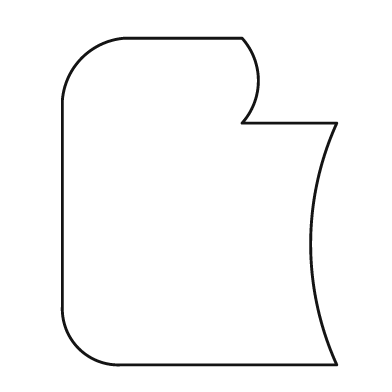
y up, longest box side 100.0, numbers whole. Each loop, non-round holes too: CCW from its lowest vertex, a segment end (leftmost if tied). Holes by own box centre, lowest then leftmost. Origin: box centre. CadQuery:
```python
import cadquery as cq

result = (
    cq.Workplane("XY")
    .moveTo(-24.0, -50.0)
    .lineTo(42.0, -50.0)
    .threePointArc((34.0, -13.0), (42.0, 24.0))
    .lineTo(13.0, 24.0)
    .threePointArc((18.0, 37.0), (13.0, 50.0))
    .lineTo(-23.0, 50.0)
    .threePointArc((-36.0, 44.0), (-42.0, 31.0))
    .lineTo(-42.0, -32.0)
    .threePointArc((-37.0, -45.0), (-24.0, -50.0))
    .close()
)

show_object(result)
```